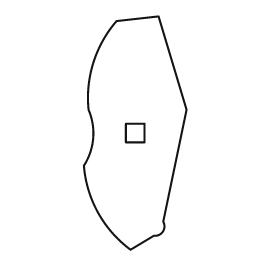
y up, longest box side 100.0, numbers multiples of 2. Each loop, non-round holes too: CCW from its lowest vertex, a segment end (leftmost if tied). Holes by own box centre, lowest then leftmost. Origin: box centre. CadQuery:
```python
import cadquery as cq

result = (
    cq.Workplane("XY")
    .moveTo(-2.0, -50.0)
    .lineTo(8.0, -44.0)
    .threePointArc((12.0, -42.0), (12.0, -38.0))
    .lineTo(22.0, 10.0)
    .lineTo(10.0, 50.0)
    .lineTo(-8.0, 48.0)
    .threePointArc((-18.0, 30.0), (-20.0, 10.0))
    .threePointArc((-18.0, -2.0), (-22.0, -14.0))
    .threePointArc((-16.0, -34.0), (-2.0, -50.0))
    .close()
    .moveTo(-4.0, -4.0)
    .lineTo(4.0, -4.0)
    .lineTo(4.0, 4.0)
    .lineTo(-4.0, 4.0)
    .close()
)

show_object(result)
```